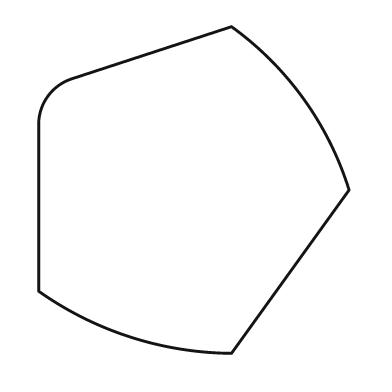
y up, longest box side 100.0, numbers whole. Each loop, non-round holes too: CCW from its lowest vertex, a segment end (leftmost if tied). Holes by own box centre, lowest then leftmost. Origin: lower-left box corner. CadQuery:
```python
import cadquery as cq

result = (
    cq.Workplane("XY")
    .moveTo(59.0, 0.0)
    .lineTo(95.0, 50.0)
    .threePointArc((81.0, 78.0), (59.0, 100.0))
    .lineTo(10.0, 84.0)
    .threePointArc((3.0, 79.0), (0.0, 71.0))
    .lineTo(0.0, 19.0)
    .threePointArc((28.0, 5.0), (59.0, 0.0))
    .close()
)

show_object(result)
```